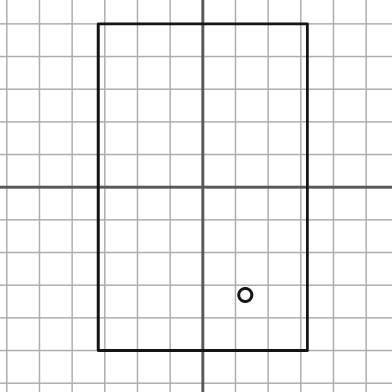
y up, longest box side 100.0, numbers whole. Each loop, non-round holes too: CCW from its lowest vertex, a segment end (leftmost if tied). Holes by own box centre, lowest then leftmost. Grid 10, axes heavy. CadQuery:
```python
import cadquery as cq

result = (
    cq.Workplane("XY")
    .moveTo(-32.0, -50.0)
    .lineTo(32.0, -50.0)
    .lineTo(32.0, 50.0)
    .lineTo(-32.0, 50.0)
    .close()
    .moveTo(13.0, -33.0)
    .circle(2.0)
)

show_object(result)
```